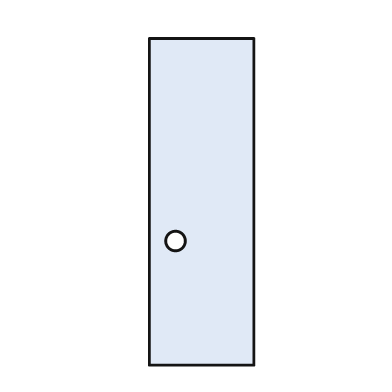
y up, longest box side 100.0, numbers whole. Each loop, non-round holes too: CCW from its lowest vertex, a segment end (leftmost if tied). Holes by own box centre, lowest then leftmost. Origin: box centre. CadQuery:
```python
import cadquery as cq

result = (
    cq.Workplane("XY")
    .moveTo(-16.0, -50.0)
    .lineTo(16.0, -50.0)
    .lineTo(16.0, 50.0)
    .lineTo(-16.0, 50.0)
    .close()
    .moveTo(-8.0, -12.0)
    .circle(3.0)
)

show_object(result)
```